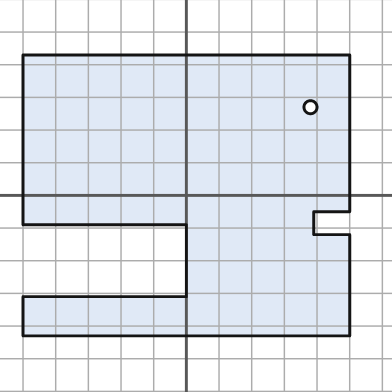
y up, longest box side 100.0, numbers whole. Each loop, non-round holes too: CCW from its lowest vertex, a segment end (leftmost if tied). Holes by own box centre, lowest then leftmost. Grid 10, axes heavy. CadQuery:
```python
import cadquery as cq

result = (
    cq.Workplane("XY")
    .moveTo(-50.0, -43.0)
    .lineTo(50.0, -43.0)
    .lineTo(50.0, -12.0)
    .lineTo(39.0, -12.0)
    .lineTo(39.0, -5.0)
    .lineTo(50.0, -5.0)
    .lineTo(50.0, 43.0)
    .lineTo(-50.0, 43.0)
    .lineTo(-50.0, -9.0)
    .lineTo(0.0, -9.0)
    .lineTo(0.0, -31.0)
    .lineTo(-50.0, -31.0)
    .close()
    .moveTo(38.0, 27.0)
    .circle(2.0)
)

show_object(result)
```